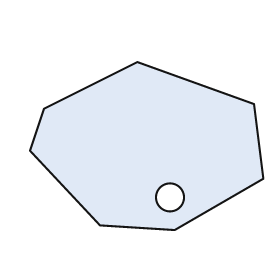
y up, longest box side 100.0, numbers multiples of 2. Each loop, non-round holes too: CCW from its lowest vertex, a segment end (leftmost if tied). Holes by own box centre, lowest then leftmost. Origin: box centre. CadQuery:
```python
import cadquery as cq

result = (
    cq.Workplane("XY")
    .moveTo(12.0, -36.0)
    .lineTo(50.0, -14.0)
    .lineTo(46.0, 18.0)
    .lineTo(-4.0, 36.0)
    .lineTo(-44.0, 16.0)
    .lineTo(-50.0, -2.0)
    .lineTo(-20.0, -34.0)
    .close()
    .moveTo(10.0, -22.0)
    .circle(6.0)
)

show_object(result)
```